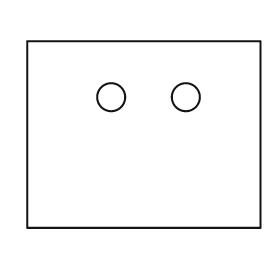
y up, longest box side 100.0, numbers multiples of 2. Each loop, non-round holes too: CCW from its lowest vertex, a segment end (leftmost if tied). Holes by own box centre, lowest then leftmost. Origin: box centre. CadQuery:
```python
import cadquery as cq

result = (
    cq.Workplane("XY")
    .moveTo(-50.0, -40.0)
    .lineTo(50.0, -40.0)
    .lineTo(50.0, 40.0)
    .lineTo(-50.0, 40.0)
    .close()
    .moveTo(-14.0, 16.0)
    .circle(6.0)
    .moveTo(18.0, 16.0)
    .circle(6.0)
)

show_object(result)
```